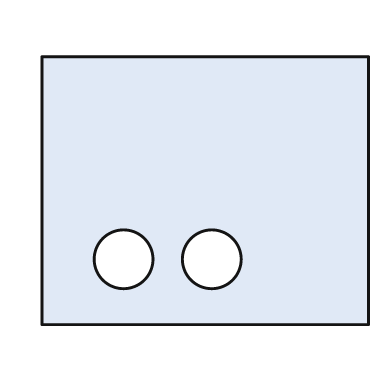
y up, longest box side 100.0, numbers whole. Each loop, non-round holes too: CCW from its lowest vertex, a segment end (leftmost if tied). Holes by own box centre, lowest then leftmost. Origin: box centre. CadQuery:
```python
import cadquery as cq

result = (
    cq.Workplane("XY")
    .moveTo(-50.0, -41.0)
    .lineTo(50.0, -41.0)
    .lineTo(50.0, 41.0)
    .lineTo(-50.0, 41.0)
    .close()
    .moveTo(-25.0, -21.0)
    .circle(9.0)
    .moveTo(2.0, -21.0)
    .circle(9.0)
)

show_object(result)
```